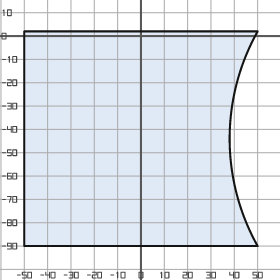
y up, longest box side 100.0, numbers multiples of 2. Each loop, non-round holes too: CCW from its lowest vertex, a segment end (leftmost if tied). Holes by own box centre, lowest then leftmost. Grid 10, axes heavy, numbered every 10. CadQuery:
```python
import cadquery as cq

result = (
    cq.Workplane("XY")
    .moveTo(-50.0, -90.0)
    .lineTo(50.0, -90.0)
    .threePointArc((38.0, -44.0), (50.0, 2.0))
    .lineTo(-50.0, 2.0)
    .close()
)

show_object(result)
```